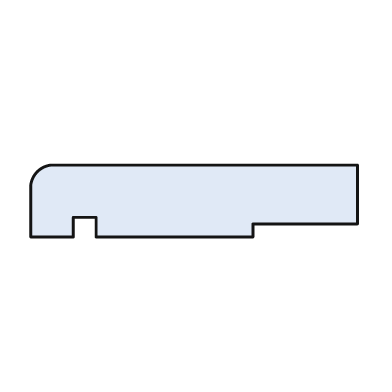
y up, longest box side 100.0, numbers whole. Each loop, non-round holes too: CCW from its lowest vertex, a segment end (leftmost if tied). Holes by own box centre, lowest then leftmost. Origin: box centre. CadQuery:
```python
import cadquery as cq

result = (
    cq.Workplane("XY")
    .moveTo(-50.0, -11.0)
    .lineTo(-37.0, -11.0)
    .lineTo(-37.0, -5.0)
    .lineTo(-30.0, -5.0)
    .lineTo(-30.0, -11.0)
    .lineTo(18.0, -11.0)
    .lineTo(18.0, -7.0)
    .lineTo(50.0, -7.0)
    .lineTo(50.0, 11.0)
    .lineTo(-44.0, 11.0)
    .threePointArc((-48.0, 9.0), (-50.0, 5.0))
    .close()
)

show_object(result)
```